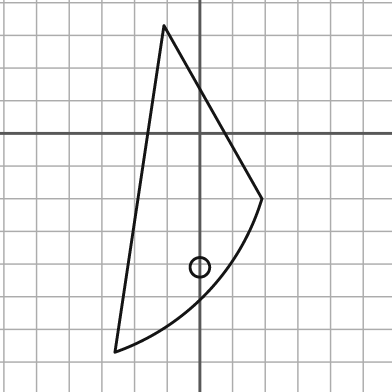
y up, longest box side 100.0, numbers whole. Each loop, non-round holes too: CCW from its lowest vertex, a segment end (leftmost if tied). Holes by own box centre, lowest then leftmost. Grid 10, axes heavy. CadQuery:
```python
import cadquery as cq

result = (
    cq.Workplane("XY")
    .moveTo(-26.0, -67.0)
    .threePointArc((2.0, -49.0), (19.0, -20.0))
    .lineTo(-11.0, 33.0)
    .close()
    .moveTo(0.0, -41.0)
    .circle(3.0)
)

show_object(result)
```